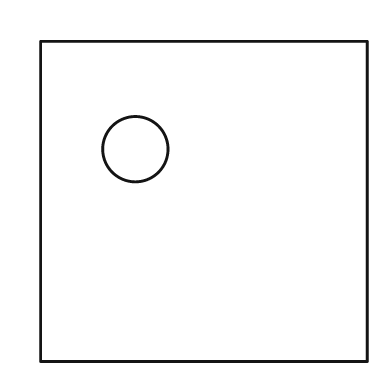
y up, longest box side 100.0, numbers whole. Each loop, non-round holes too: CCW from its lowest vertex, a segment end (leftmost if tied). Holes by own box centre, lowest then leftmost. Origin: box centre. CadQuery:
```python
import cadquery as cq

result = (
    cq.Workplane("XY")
    .moveTo(-50.0, -49.0)
    .lineTo(50.0, -49.0)
    .lineTo(50.0, 49.0)
    .lineTo(-50.0, 49.0)
    .close()
    .moveTo(-21.0, 16.0)
    .circle(10.0)
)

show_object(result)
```